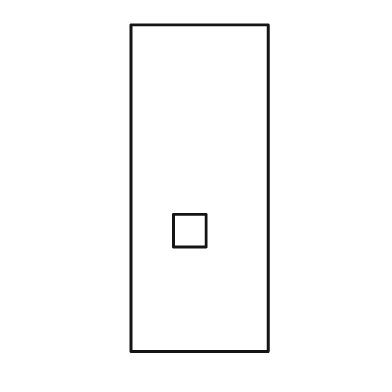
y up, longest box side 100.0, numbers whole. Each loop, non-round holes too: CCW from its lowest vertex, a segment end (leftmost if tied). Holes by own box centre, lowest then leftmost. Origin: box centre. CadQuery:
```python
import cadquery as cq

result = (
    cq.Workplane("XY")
    .moveTo(-21.0, -50.0)
    .lineTo(21.0, -50.0)
    .lineTo(21.0, 50.0)
    .lineTo(-21.0, 50.0)
    .close()
    .moveTo(-8.0, -18.0)
    .lineTo(2.0, -18.0)
    .lineTo(2.0, -8.0)
    .lineTo(-8.0, -8.0)
    .close()
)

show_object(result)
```